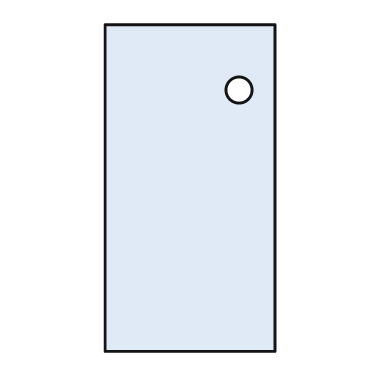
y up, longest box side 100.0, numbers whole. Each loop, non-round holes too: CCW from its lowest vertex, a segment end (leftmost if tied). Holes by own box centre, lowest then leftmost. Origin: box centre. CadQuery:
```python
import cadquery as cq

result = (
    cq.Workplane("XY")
    .moveTo(-26.0, -50.0)
    .lineTo(26.0, -50.0)
    .lineTo(26.0, 50.0)
    .lineTo(-26.0, 50.0)
    .close()
    .moveTo(15.0, 30.0)
    .circle(4.0)
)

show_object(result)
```